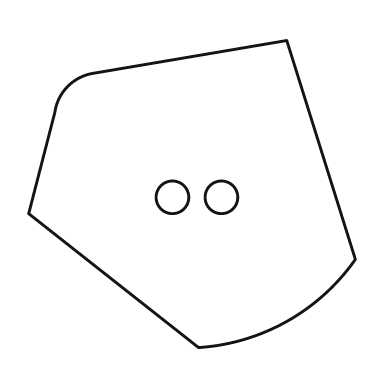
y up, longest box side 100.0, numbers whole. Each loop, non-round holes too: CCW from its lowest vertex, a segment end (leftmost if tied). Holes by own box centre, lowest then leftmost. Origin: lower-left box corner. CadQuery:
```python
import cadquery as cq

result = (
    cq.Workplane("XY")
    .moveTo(52.0, 0.0)
    .threePointArc((79.0, 8.0), (100.0, 27.0))
    .lineTo(79.0, 94.0)
    .lineTo(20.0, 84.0)
    .threePointArc((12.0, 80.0), (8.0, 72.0))
    .lineTo(0.0, 41.0)
    .close()
    .moveTo(44.0, 46.0)
    .circle(5.0)
    .moveTo(59.0, 46.0)
    .circle(5.0)
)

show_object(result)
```